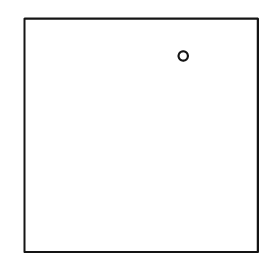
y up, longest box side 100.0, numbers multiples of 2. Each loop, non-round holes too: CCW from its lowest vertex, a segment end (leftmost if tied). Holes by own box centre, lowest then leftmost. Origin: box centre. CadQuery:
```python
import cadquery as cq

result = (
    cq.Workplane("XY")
    .moveTo(-50.0, -50.0)
    .lineTo(50.0, -50.0)
    .lineTo(50.0, 50.0)
    .lineTo(-50.0, 50.0)
    .close()
    .moveTo(18.0, 34.0)
    .circle(2.0)
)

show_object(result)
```